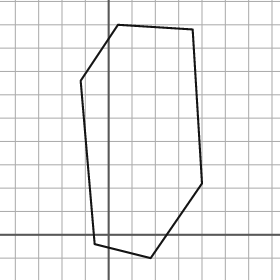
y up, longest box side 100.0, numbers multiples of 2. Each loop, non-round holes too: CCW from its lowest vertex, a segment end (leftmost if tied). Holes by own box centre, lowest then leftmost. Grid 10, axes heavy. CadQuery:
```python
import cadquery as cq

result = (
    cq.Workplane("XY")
    .moveTo(18.0, -10.0)
    .lineTo(40.0, 22.0)
    .lineTo(36.0, 88.0)
    .lineTo(4.0, 90.0)
    .lineTo(-12.0, 66.0)
    .lineTo(-6.0, -4.0)
    .close()
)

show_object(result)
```